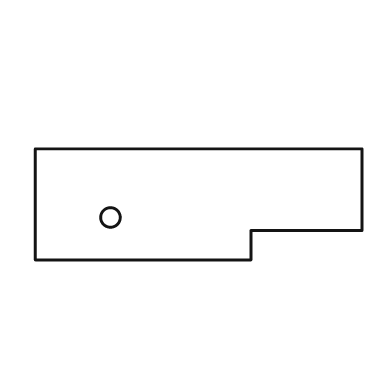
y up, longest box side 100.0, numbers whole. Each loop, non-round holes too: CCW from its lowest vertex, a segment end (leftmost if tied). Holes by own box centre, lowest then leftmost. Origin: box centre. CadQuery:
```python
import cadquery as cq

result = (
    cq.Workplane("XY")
    .moveTo(-50.0, -17.0)
    .lineTo(16.0, -17.0)
    .lineTo(16.0, -8.0)
    .lineTo(50.0, -8.0)
    .lineTo(50.0, 17.0)
    .lineTo(-50.0, 17.0)
    .close()
    .moveTo(-27.0, -4.0)
    .circle(3.0)
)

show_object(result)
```